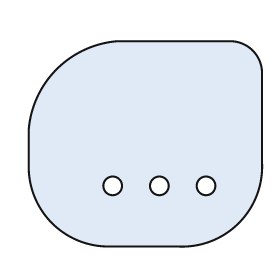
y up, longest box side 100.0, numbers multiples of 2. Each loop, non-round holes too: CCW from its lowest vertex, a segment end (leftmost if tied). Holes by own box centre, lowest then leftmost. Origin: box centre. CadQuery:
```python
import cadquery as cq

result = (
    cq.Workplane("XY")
    .moveTo(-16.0, -44.0)
    .lineTo(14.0, -44.0)
    .threePointArc((40.0, -34.0), (50.0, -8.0))
    .lineTo(50.0, 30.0)
    .threePointArc((46.0, 40.0), (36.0, 44.0))
    .lineTo(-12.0, 44.0)
    .threePointArc((-38.0, 32.0), (-50.0, 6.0))
    .lineTo(-50.0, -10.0)
    .threePointArc((-40.0, -34.0), (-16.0, -44.0))
    .close()
    .moveTo(-14.0, -18.0)
    .circle(4.0)
    .moveTo(6.0, -18.0)
    .circle(4.0)
    .moveTo(26.0, -18.0)
    .circle(4.0)
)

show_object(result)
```